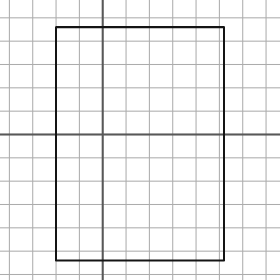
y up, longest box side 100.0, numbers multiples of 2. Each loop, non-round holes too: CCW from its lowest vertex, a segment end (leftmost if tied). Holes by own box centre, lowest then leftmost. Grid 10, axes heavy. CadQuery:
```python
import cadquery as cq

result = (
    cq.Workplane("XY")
    .moveTo(-20.0, -54.0)
    .lineTo(52.0, -54.0)
    .lineTo(52.0, 46.0)
    .lineTo(-20.0, 46.0)
    .close()
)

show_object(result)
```